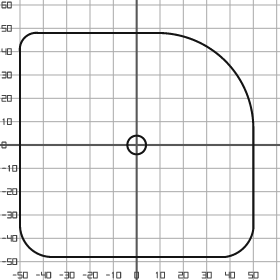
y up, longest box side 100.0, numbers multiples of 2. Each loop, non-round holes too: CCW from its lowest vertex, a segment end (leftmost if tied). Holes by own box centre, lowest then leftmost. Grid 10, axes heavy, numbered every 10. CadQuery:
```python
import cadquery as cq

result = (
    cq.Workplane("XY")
    .moveTo(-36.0, -48.0)
    .lineTo(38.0, -48.0)
    .threePointArc((46.0, -44.0), (50.0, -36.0))
    .lineTo(50.0, 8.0)
    .threePointArc((38.0, 36.0), (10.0, 48.0))
    .lineTo(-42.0, 48.0)
    .threePointArc((-48.0, 46.0), (-50.0, 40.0))
    .lineTo(-50.0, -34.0)
    .threePointArc((-46.0, -44.0), (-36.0, -48.0))
    .close()
    .moveTo(0.0, 0.0)
    .circle(4.0)
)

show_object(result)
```